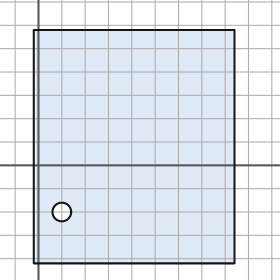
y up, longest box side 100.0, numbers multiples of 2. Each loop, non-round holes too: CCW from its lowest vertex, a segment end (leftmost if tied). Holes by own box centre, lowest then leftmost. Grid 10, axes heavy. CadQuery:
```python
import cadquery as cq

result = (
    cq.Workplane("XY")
    .moveTo(-2.0, -42.0)
    .lineTo(84.0, -42.0)
    .lineTo(84.0, 58.0)
    .lineTo(-2.0, 58.0)
    .close()
    .moveTo(10.0, -20.0)
    .circle(4.0)
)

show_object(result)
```